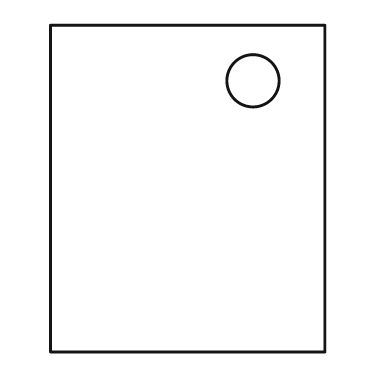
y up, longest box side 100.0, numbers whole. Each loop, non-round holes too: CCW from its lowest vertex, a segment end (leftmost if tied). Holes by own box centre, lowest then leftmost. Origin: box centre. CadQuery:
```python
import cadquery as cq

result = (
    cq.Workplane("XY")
    .moveTo(-42.0, -50.0)
    .lineTo(42.0, -50.0)
    .lineTo(42.0, 50.0)
    .lineTo(-42.0, 50.0)
    .close()
    .moveTo(20.0, 33.0)
    .circle(8.0)
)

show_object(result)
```